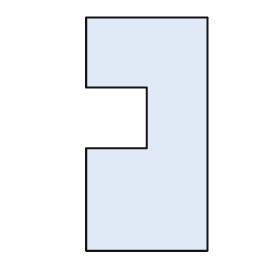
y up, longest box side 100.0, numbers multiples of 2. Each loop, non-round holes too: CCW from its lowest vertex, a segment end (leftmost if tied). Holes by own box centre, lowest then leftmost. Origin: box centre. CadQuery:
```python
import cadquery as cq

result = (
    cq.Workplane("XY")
    .moveTo(-26.0, -50.0)
    .lineTo(26.0, -50.0)
    .lineTo(26.0, 50.0)
    .lineTo(-26.0, 50.0)
    .lineTo(-26.0, 20.0)
    .lineTo(0.0, 20.0)
    .lineTo(0.0, -6.0)
    .lineTo(-26.0, -6.0)
    .close()
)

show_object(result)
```